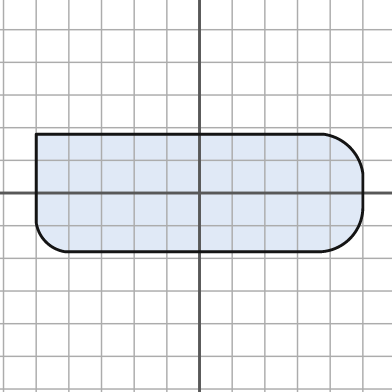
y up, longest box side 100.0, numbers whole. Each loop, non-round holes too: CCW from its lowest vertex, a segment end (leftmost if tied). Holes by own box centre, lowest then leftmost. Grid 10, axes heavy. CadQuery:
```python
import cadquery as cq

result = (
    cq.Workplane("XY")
    .moveTo(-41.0, -18.0)
    .lineTo(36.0, -18.0)
    .threePointArc((46.0, -14.0), (50.0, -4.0))
    .lineTo(50.0, 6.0)
    .threePointArc((46.0, 14.0), (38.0, 18.0))
    .lineTo(-50.0, 18.0)
    .lineTo(-50.0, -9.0)
    .threePointArc((-47.0, -15.0), (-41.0, -18.0))
    .close()
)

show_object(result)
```